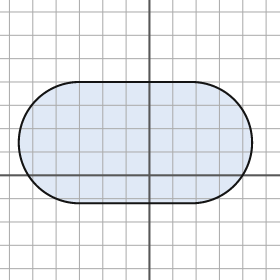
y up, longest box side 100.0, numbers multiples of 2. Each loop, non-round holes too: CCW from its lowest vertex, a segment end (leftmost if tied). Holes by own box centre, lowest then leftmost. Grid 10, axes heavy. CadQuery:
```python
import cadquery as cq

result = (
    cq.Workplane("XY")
    .moveTo(-30.0, -12.0)
    .lineTo(18.0, -12.0)
    .threePointArc((44.0, 14.0), (18.0, 40.0))
    .lineTo(-30.0, 40.0)
    .threePointArc((-56.0, 14.0), (-30.0, -12.0))
    .close()
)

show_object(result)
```